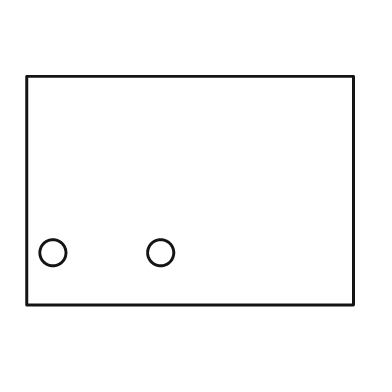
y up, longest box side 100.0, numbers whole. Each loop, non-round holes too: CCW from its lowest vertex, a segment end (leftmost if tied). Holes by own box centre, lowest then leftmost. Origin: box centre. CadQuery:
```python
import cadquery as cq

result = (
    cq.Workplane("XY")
    .moveTo(-50.0, -35.0)
    .lineTo(50.0, -35.0)
    .lineTo(50.0, 35.0)
    .lineTo(-50.0, 35.0)
    .close()
    .moveTo(-42.0, -19.0)
    .circle(4.0)
    .moveTo(-9.0, -19.0)
    .circle(4.0)
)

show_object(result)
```